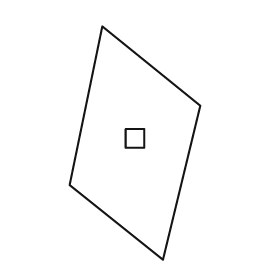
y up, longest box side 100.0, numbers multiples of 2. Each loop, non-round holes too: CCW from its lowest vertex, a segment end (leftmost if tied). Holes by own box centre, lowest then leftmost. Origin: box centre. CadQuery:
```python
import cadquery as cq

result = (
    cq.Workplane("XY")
    .moveTo(12.0, -50.0)
    .lineTo(28.0, 16.0)
    .lineTo(-14.0, 50.0)
    .lineTo(-28.0, -18.0)
    .close()
    .moveTo(-4.0, -2.0)
    .lineTo(4.0, -2.0)
    .lineTo(4.0, 6.0)
    .lineTo(-4.0, 6.0)
    .close()
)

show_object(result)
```